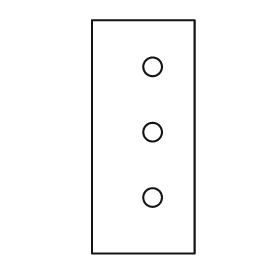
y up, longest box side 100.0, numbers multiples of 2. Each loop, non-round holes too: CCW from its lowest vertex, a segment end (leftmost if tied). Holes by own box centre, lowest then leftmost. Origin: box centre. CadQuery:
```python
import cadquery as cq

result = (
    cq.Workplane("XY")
    .moveTo(-22.0, -50.0)
    .lineTo(22.0, -50.0)
    .lineTo(22.0, 50.0)
    .lineTo(-22.0, 50.0)
    .close()
    .moveTo(4.0, -26.0)
    .circle(4.0)
    .moveTo(4.0, 2.0)
    .circle(4.0)
    .moveTo(4.0, 30.0)
    .circle(4.0)
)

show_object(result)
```